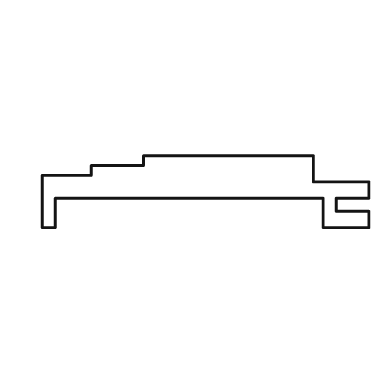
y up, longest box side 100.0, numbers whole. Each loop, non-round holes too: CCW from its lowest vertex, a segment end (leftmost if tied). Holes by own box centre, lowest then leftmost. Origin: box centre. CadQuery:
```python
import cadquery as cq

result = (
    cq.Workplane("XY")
    .moveTo(-50.0, -11.0)
    .lineTo(-46.0, -11.0)
    .lineTo(-46.0, -2.0)
    .lineTo(36.0, -2.0)
    .lineTo(36.0, -11.0)
    .lineTo(50.0, -11.0)
    .lineTo(50.0, -6.0)
    .lineTo(40.0, -6.0)
    .lineTo(40.0, -2.0)
    .lineTo(50.0, -2.0)
    .lineTo(50.0, 3.0)
    .lineTo(33.0, 3.0)
    .lineTo(33.0, 11.0)
    .lineTo(-19.0, 11.0)
    .lineTo(-19.0, 8.0)
    .lineTo(-35.0, 8.0)
    .lineTo(-35.0, 5.0)
    .lineTo(-50.0, 5.0)
    .close()
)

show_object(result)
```